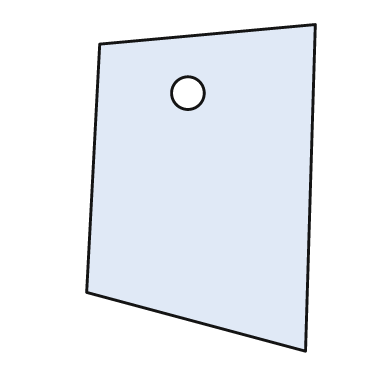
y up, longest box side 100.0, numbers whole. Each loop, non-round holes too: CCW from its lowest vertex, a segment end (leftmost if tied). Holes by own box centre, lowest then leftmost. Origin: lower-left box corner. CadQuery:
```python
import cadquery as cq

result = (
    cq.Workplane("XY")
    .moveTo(67.0, 0.0)
    .lineTo(70.0, 100.0)
    .lineTo(4.0, 94.0)
    .lineTo(0.0, 18.0)
    .close()
    .moveTo(31.0, 79.0)
    .circle(5.0)
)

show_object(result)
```